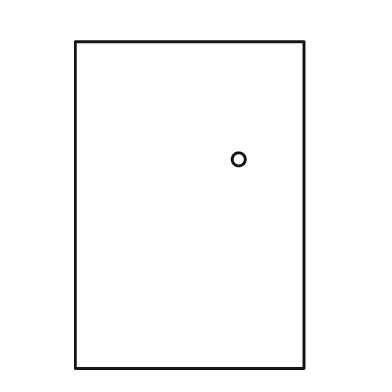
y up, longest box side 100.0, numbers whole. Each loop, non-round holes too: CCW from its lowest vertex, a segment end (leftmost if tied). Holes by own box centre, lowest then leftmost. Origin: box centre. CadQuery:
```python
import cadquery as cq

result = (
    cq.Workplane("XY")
    .moveTo(-35.0, -50.0)
    .lineTo(35.0, -50.0)
    .lineTo(35.0, 50.0)
    .lineTo(-35.0, 50.0)
    .close()
    .moveTo(15.0, 14.0)
    .circle(2.0)
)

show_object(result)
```